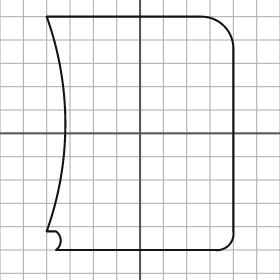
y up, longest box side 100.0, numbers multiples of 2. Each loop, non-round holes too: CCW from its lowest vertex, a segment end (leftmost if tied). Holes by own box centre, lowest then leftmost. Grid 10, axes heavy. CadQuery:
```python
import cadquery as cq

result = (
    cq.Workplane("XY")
    .moveTo(-36.0, -50.0)
    .lineTo(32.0, -50.0)
    .threePointArc((38.0, -48.0), (40.0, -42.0))
    .lineTo(40.0, 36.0)
    .threePointArc((36.0, 46.0), (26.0, 50.0))
    .lineTo(-40.0, 50.0)
    .threePointArc((-32.0, 4.0), (-40.0, -42.0))
    .lineTo(-36.0, -42.0)
    .threePointArc((-34.0, -46.0), (-36.0, -50.0))
    .close()
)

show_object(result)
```